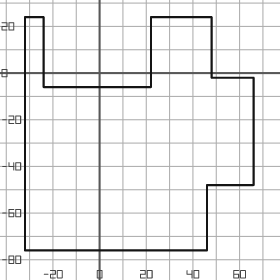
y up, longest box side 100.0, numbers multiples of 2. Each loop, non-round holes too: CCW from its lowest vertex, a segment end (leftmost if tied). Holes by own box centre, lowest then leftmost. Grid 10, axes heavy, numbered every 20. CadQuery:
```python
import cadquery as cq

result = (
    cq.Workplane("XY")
    .moveTo(-32.0, -76.0)
    .lineTo(46.0, -76.0)
    .lineTo(46.0, -48.0)
    .lineTo(66.0, -48.0)
    .lineTo(66.0, -2.0)
    .lineTo(48.0, -2.0)
    .lineTo(48.0, 24.0)
    .lineTo(22.0, 24.0)
    .lineTo(22.0, -6.0)
    .lineTo(-24.0, -6.0)
    .lineTo(-24.0, 24.0)
    .lineTo(-32.0, 24.0)
    .close()
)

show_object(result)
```